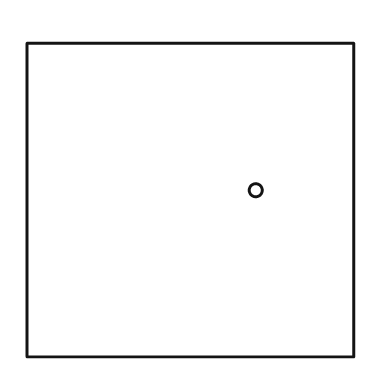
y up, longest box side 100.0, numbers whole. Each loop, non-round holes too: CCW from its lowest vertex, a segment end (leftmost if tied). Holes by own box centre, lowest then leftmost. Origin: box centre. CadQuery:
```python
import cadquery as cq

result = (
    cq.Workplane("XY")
    .moveTo(-50.0, -48.0)
    .lineTo(50.0, -48.0)
    .lineTo(50.0, 48.0)
    .lineTo(-50.0, 48.0)
    .close()
    .moveTo(20.0, 3.0)
    .circle(2.0)
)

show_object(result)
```